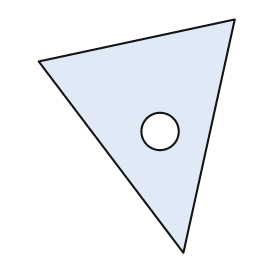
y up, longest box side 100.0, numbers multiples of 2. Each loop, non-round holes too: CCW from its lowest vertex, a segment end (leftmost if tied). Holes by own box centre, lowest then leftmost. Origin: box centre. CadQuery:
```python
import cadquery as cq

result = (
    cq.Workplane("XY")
    .moveTo(20.0, -50.0)
    .lineTo(42.0, 50.0)
    .lineTo(-42.0, 32.0)
    .close()
    .moveTo(10.0, 2.0)
    .circle(8.0)
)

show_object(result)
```